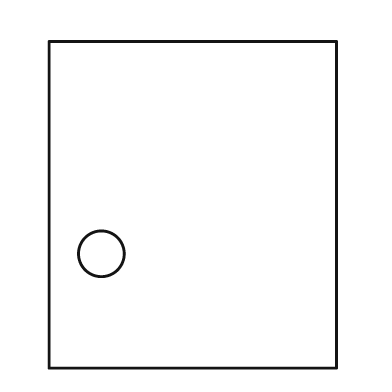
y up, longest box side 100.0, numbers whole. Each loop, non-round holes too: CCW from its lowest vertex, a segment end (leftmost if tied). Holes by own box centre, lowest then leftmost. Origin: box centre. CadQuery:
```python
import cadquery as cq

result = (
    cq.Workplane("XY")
    .moveTo(-44.0, -50.0)
    .lineTo(44.0, -50.0)
    .lineTo(44.0, 50.0)
    .lineTo(-44.0, 50.0)
    .close()
    .moveTo(-28.0, -15.0)
    .circle(7.0)
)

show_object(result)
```